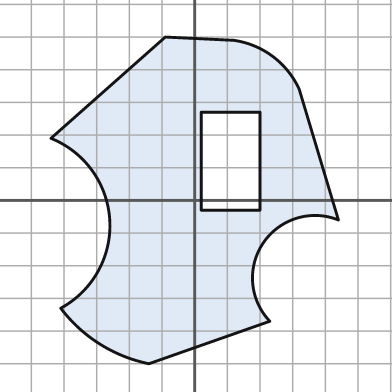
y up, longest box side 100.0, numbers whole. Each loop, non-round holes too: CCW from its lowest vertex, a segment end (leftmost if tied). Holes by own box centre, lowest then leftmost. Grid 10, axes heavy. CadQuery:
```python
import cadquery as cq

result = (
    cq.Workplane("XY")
    .moveTo(-14.0, -50.0)
    .lineTo(23.0, -37.0)
    .threePointArc((21.0, -13.0), (44.0, -6.0))
    .lineTo(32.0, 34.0)
    .threePointArc((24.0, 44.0), (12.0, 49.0))
    .lineTo(-9.0, 50.0)
    .lineTo(-44.0, 19.0)
    .threePointArc((-26.0, -6.0), (-41.0, -33.0))
    .threePointArc((-29.0, -44.0), (-14.0, -50.0))
    .close()
    .moveTo(2.0, -3.0)
    .lineTo(20.0, -3.0)
    .lineTo(20.0, 27.0)
    .lineTo(2.0, 27.0)
    .close()
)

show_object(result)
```